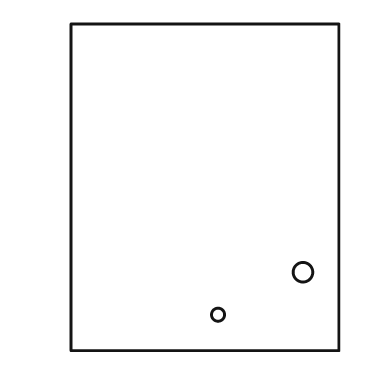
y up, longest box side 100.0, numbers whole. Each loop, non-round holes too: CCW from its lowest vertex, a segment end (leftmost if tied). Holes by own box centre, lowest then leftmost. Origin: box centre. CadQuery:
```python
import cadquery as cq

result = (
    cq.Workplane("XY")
    .moveTo(-41.0, -50.0)
    .lineTo(41.0, -50.0)
    .lineTo(41.0, 50.0)
    .lineTo(-41.0, 50.0)
    .close()
    .moveTo(4.0, -39.0)
    .circle(2.0)
    .moveTo(30.0, -26.0)
    .circle(3.0)
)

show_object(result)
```